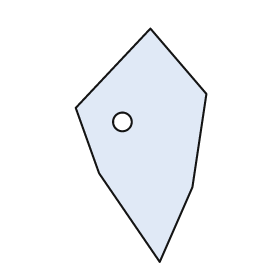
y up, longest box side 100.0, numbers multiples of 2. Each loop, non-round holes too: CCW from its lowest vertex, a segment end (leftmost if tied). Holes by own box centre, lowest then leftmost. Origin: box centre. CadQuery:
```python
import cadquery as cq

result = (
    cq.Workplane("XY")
    .moveTo(8.0, -50.0)
    .lineTo(22.0, -18.0)
    .lineTo(28.0, 22.0)
    .lineTo(4.0, 50.0)
    .lineTo(-28.0, 16.0)
    .lineTo(-18.0, -12.0)
    .close()
    .moveTo(-8.0, 10.0)
    .circle(4.0)
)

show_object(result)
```